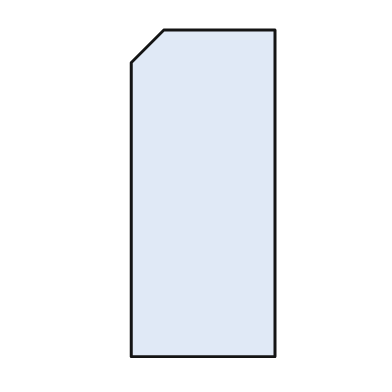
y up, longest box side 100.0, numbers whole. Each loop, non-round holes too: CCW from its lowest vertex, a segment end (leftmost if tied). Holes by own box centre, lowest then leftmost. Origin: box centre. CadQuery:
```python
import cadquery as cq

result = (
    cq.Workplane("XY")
    .moveTo(-22.0, -50.0)
    .lineTo(22.0, -50.0)
    .lineTo(22.0, 50.0)
    .lineTo(-12.0, 50.0)
    .lineTo(-22.0, 40.0)
    .close()
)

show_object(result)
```